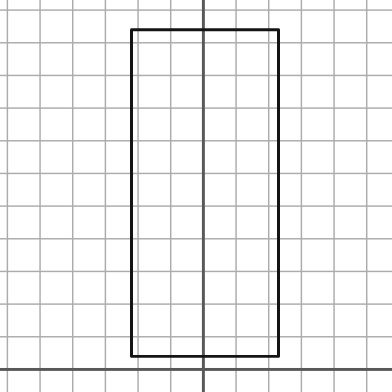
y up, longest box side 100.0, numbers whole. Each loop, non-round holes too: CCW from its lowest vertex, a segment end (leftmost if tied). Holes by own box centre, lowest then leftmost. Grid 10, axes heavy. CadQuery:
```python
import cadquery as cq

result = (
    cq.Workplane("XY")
    .moveTo(-22.0, 4.0)
    .lineTo(23.0, 4.0)
    .lineTo(23.0, 104.0)
    .lineTo(-22.0, 104.0)
    .close()
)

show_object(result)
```